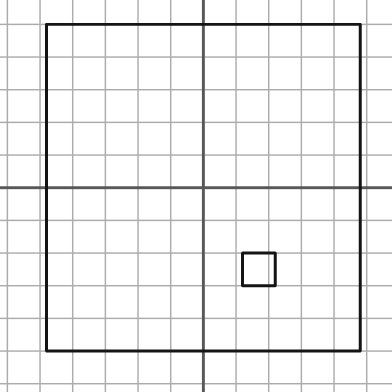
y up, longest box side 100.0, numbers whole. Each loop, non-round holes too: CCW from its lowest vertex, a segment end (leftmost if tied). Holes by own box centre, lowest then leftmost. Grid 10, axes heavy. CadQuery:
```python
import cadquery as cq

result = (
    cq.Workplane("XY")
    .moveTo(-48.0, -50.0)
    .lineTo(48.0, -50.0)
    .lineTo(48.0, 50.0)
    .lineTo(-48.0, 50.0)
    .close()
    .moveTo(12.0, -30.0)
    .lineTo(22.0, -30.0)
    .lineTo(22.0, -20.0)
    .lineTo(12.0, -20.0)
    .close()
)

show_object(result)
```